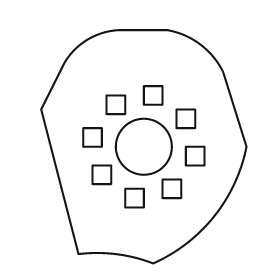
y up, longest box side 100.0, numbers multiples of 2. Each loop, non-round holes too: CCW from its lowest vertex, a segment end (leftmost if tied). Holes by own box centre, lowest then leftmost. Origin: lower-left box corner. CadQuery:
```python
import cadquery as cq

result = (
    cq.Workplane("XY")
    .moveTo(48.0, 0.0)
    .threePointArc((74.0, 20.0), (88.0, 50.0))
    .lineTo(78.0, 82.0)
    .threePointArc((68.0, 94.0), (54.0, 100.0))
    .lineTo(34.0, 100.0)
    .threePointArc((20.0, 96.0), (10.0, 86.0))
    .lineTo(0.0, 66.0)
    .lineTo(16.0, 4.0)
    .threePointArc((32.0, 4.0), (48.0, 0.0))
    .close()
    .moveTo(36.0, 24.0)
    .lineTo(44.0, 24.0)
    .lineTo(44.0, 32.0)
    .lineTo(36.0, 32.0)
    .close()
    .moveTo(52.0, 28.0)
    .lineTo(60.0, 28.0)
    .lineTo(60.0, 36.0)
    .lineTo(52.0, 36.0)
    .close()
    .moveTo(22.0, 34.0)
    .lineTo(30.0, 34.0)
    .lineTo(30.0, 42.0)
    .lineTo(22.0, 42.0)
    .close()
    .moveTo(62.0, 42.0)
    .lineTo(70.0, 42.0)
    .lineTo(70.0, 50.0)
    .lineTo(62.0, 50.0)
    .close()
    .moveTo(44.0, 50.0)
    .circle(12.0)
    .moveTo(18.0, 50.0)
    .lineTo(26.0, 50.0)
    .lineTo(26.0, 58.0)
    .lineTo(18.0, 58.0)
    .close()
    .moveTo(58.0, 58.0)
    .lineTo(66.0, 58.0)
    .lineTo(66.0, 66.0)
    .lineTo(58.0, 66.0)
    .close()
    .moveTo(28.0, 64.0)
    .lineTo(36.0, 64.0)
    .lineTo(36.0, 72.0)
    .lineTo(28.0, 72.0)
    .close()
    .moveTo(44.0, 68.0)
    .lineTo(52.0, 68.0)
    .lineTo(52.0, 76.0)
    .lineTo(44.0, 76.0)
    .close()
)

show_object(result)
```